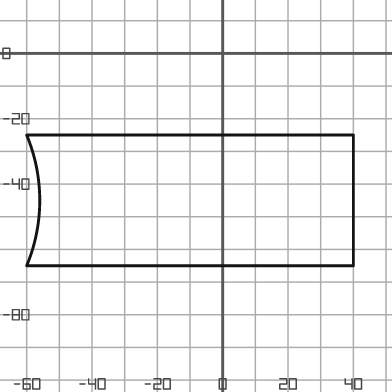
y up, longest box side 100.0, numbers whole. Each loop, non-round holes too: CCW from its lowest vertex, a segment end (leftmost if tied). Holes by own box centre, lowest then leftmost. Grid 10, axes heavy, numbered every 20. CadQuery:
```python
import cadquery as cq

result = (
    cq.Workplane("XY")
    .moveTo(-60.0, -65.0)
    .lineTo(40.0, -65.0)
    .lineTo(40.0, -25.0)
    .lineTo(-60.0, -25.0)
    .threePointArc((-56.0, -45.0), (-60.0, -65.0))
    .close()
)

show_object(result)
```